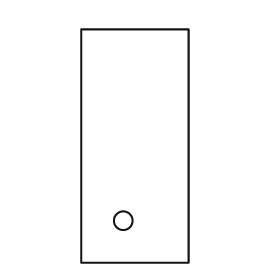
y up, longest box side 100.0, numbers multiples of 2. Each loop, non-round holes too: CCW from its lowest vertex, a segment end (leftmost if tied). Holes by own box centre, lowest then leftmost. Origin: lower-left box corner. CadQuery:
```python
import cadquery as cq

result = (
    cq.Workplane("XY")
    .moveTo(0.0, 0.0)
    .lineTo(46.0, 0.0)
    .lineTo(46.0, 100.0)
    .lineTo(0.0, 100.0)
    .close()
    .moveTo(18.0, 18.0)
    .circle(4.0)
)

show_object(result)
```